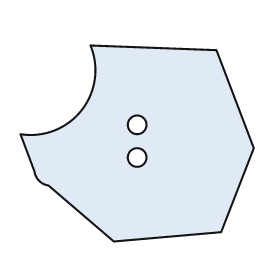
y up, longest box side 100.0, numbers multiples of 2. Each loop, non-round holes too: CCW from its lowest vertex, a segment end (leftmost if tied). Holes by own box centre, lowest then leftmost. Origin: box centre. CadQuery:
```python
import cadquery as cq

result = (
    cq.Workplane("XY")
    .moveTo(-10.0, -42.0)
    .lineTo(36.0, -38.0)
    .lineTo(50.0, -2.0)
    .lineTo(34.0, 40.0)
    .lineTo(-20.0, 42.0)
    .threePointArc((-24.0, 14.0), (-50.0, 4.0))
    .lineTo(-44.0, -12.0)
    .threePointArc((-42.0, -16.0), (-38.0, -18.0))
    .close()
    .moveTo(0.0, -6.0)
    .circle(4.0)
    .moveTo(0.0, 8.0)
    .circle(4.0)
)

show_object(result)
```